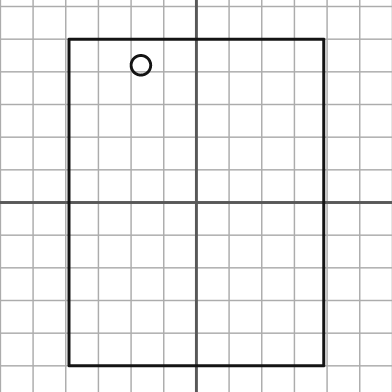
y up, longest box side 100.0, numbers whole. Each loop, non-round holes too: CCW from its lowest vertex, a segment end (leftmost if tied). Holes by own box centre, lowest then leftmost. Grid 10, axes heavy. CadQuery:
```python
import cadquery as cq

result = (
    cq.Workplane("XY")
    .moveTo(-39.0, -50.0)
    .lineTo(39.0, -50.0)
    .lineTo(39.0, 50.0)
    .lineTo(-39.0, 50.0)
    .close()
    .moveTo(-17.0, 42.0)
    .circle(3.0)
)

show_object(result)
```